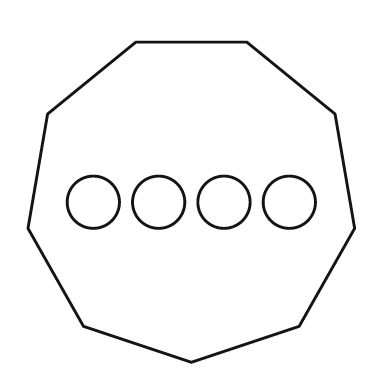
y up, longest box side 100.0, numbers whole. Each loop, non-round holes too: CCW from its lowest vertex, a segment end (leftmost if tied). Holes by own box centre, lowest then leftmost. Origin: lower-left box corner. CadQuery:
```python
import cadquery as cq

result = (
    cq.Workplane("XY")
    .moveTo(50.0, 0.0)
    .lineTo(83.0, 11.0)
    .lineTo(100.0, 41.0)
    .lineTo(94.0, 76.0)
    .lineTo(67.0, 98.0)
    .lineTo(33.0, 98.0)
    .lineTo(6.0, 76.0)
    .lineTo(0.0, 41.0)
    .lineTo(17.0, 11.0)
    .close()
    .moveTo(20.0, 49.0)
    .circle(8.0)
    .moveTo(40.0, 49.0)
    .circle(8.0)
    .moveTo(60.0, 49.0)
    .circle(8.0)
    .moveTo(80.0, 49.0)
    .circle(8.0)
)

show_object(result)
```